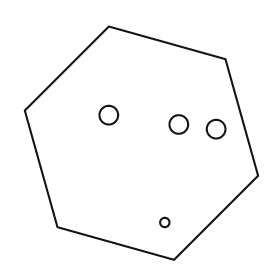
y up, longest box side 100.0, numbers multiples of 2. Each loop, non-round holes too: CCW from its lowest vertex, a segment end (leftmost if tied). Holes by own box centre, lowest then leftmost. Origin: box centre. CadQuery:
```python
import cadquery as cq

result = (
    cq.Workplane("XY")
    .moveTo(14.0, -50.0)
    .lineTo(50.0, -14.0)
    .lineTo(36.0, 36.0)
    .lineTo(-14.0, 50.0)
    .lineTo(-50.0, 14.0)
    .lineTo(-36.0, -36.0)
    .close()
    .moveTo(10.0, -34.0)
    .circle(2.0)
    .moveTo(32.0, 6.0)
    .circle(4.0)
    .moveTo(16.0, 8.0)
    .circle(4.0)
    .moveTo(-14.0, 12.0)
    .circle(4.0)
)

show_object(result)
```